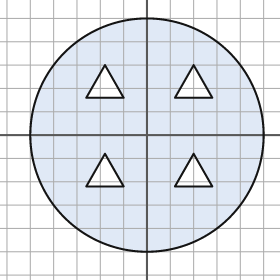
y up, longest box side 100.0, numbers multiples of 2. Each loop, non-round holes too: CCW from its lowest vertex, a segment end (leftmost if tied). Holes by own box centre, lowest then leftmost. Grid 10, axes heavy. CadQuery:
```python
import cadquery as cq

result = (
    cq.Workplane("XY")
    .moveTo(0.0, 0.0)
    .circle(50.0)
    .moveTo(-26.0, -22.0)
    .lineTo(-10.0, -22.0)
    .lineTo(-18.0, -8.0)
    .close()
    .moveTo(12.0, -22.0)
    .lineTo(28.0, -22.0)
    .lineTo(20.0, -8.0)
    .close()
    .moveTo(-26.0, 16.0)
    .lineTo(-10.0, 16.0)
    .lineTo(-18.0, 30.0)
    .close()
    .moveTo(12.0, 16.0)
    .lineTo(28.0, 16.0)
    .lineTo(20.0, 30.0)
    .close()
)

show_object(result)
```